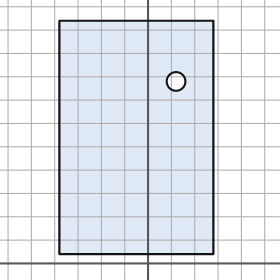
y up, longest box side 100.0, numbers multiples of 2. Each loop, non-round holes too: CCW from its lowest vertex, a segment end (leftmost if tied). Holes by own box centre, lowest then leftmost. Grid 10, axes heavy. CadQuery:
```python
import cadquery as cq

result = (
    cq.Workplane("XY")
    .moveTo(-38.0, 4.0)
    .lineTo(28.0, 4.0)
    .lineTo(28.0, 104.0)
    .lineTo(-38.0, 104.0)
    .close()
    .moveTo(12.0, 78.0)
    .circle(4.0)
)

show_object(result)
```